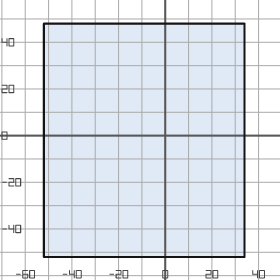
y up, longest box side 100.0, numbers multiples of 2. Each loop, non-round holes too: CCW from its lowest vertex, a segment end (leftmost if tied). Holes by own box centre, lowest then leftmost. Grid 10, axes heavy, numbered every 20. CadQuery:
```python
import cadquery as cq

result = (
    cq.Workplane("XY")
    .moveTo(-52.0, -52.0)
    .lineTo(34.0, -52.0)
    .lineTo(34.0, 48.0)
    .lineTo(-52.0, 48.0)
    .close()
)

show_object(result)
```